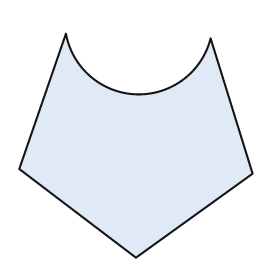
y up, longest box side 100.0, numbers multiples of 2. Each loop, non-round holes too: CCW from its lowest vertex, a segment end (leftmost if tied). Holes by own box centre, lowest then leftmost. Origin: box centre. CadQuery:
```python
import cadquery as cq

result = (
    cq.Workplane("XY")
    .moveTo(0.0, -48.0)
    .lineTo(50.0, -12.0)
    .lineTo(32.0, 46.0)
    .threePointArc((0.0, 22.0), (-30.0, 48.0))
    .lineTo(-50.0, -10.0)
    .close()
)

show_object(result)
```